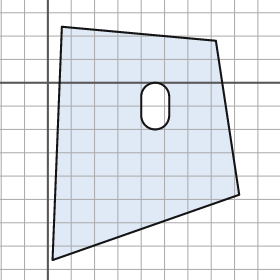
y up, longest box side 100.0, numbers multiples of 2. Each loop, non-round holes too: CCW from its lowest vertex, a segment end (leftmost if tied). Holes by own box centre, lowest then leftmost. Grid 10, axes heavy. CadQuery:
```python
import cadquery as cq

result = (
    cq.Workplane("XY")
    .moveTo(2.0, -76.0)
    .lineTo(82.0, -48.0)
    .lineTo(72.0, 18.0)
    .lineTo(6.0, 24.0)
    .close()
    .moveTo(40.0, -14.0)
    .threePointArc((46.0, -20.0), (52.0, -14.0))
    .lineTo(52.0, -6.0)
    .threePointArc((46.0, 0.0), (40.0, -6.0))
    .close()
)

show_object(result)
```